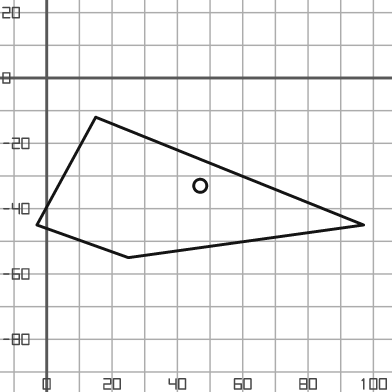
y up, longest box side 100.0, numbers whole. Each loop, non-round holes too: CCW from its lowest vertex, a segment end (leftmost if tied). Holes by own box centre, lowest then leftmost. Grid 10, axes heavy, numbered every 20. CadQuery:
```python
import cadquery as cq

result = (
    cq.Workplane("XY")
    .moveTo(25.0, -55.0)
    .lineTo(97.0, -45.0)
    .lineTo(15.0, -12.0)
    .lineTo(-3.0, -45.0)
    .close()
    .moveTo(47.0, -33.0)
    .circle(2.0)
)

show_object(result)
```